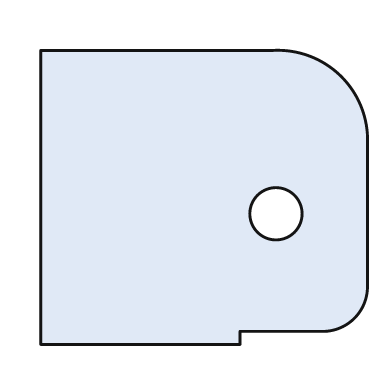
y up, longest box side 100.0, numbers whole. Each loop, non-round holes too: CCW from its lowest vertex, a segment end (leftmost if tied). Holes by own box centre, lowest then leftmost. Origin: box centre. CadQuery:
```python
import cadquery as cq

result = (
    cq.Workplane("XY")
    .moveTo(-50.0, -45.0)
    .lineTo(11.0, -45.0)
    .lineTo(11.0, -41.0)
    .lineTo(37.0, -41.0)
    .threePointArc((46.0, -37.0), (50.0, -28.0))
    .lineTo(50.0, 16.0)
    .threePointArc((42.0, 37.0), (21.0, 45.0))
    .lineTo(-50.0, 45.0)
    .close()
    .moveTo(22.0, -5.0)
    .circle(8.0)
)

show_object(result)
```